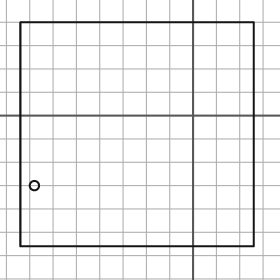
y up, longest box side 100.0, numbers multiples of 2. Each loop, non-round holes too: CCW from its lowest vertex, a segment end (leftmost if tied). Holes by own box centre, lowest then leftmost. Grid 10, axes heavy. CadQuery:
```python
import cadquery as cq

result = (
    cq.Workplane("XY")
    .moveTo(-74.0, -56.0)
    .lineTo(26.0, -56.0)
    .lineTo(26.0, 40.0)
    .lineTo(-74.0, 40.0)
    .close()
    .moveTo(-68.0, -30.0)
    .circle(2.0)
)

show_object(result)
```